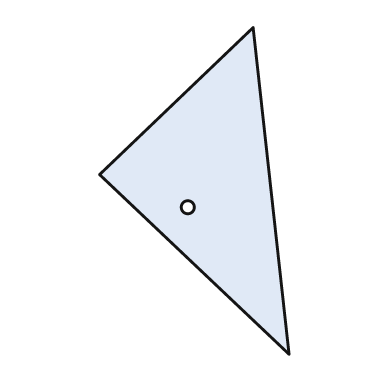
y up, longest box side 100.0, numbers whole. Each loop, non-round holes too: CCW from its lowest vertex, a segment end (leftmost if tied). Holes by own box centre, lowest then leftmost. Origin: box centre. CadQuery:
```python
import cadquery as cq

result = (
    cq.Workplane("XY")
    .moveTo(29.0, -50.0)
    .lineTo(18.0, 50.0)
    .lineTo(-29.0, 5.0)
    .close()
    .moveTo(-2.0, -5.0)
    .circle(2.0)
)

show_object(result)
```